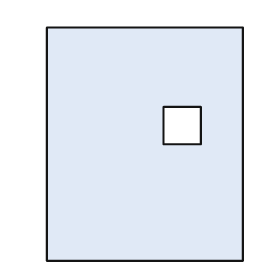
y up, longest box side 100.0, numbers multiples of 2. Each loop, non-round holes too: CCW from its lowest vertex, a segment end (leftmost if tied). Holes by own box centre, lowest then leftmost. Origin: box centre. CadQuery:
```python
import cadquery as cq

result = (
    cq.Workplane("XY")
    .moveTo(-42.0, -50.0)
    .lineTo(42.0, -50.0)
    .lineTo(42.0, 50.0)
    .lineTo(-42.0, 50.0)
    .close()
    .moveTo(8.0, 0.0)
    .lineTo(24.0, 0.0)
    .lineTo(24.0, 16.0)
    .lineTo(8.0, 16.0)
    .close()
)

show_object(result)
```